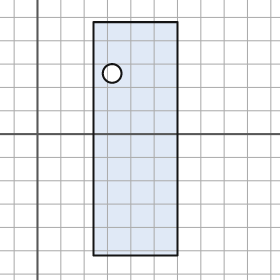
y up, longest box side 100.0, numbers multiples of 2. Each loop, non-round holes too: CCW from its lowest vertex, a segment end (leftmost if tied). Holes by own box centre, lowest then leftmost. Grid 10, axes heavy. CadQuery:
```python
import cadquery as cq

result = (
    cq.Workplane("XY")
    .moveTo(24.0, -52.0)
    .lineTo(60.0, -52.0)
    .lineTo(60.0, 48.0)
    .lineTo(24.0, 48.0)
    .close()
    .moveTo(32.0, 26.0)
    .circle(4.0)
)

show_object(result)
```